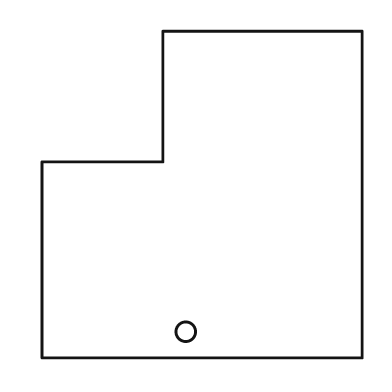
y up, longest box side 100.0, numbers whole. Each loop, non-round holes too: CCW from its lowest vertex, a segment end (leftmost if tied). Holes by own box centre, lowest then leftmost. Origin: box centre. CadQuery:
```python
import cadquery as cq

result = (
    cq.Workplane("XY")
    .moveTo(-49.0, -50.0)
    .lineTo(49.0, -50.0)
    .lineTo(49.0, 50.0)
    .lineTo(-12.0, 50.0)
    .lineTo(-12.0, 10.0)
    .lineTo(-49.0, 10.0)
    .close()
    .moveTo(-5.0, -42.0)
    .circle(3.0)
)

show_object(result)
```